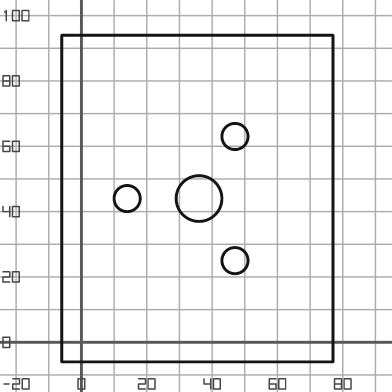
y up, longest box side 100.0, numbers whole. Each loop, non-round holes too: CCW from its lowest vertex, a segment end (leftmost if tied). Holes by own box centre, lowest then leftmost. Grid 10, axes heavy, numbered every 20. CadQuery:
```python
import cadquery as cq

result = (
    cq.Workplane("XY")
    .moveTo(-6.0, -6.0)
    .lineTo(77.0, -6.0)
    .lineTo(77.0, 94.0)
    .lineTo(-6.0, 94.0)
    .close()
    .moveTo(47.0, 25.0)
    .circle(4.0)
    .moveTo(14.0, 44.0)
    .circle(4.0)
    .moveTo(36.0, 44.0)
    .circle(7.0)
    .moveTo(47.0, 63.0)
    .circle(4.0)
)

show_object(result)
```